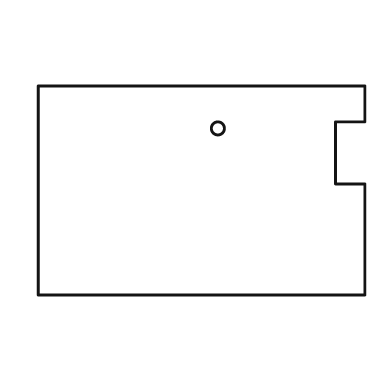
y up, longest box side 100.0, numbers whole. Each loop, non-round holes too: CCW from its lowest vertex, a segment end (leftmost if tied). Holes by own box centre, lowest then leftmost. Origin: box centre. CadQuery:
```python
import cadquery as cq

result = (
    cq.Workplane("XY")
    .moveTo(-50.0, -32.0)
    .lineTo(50.0, -32.0)
    .lineTo(50.0, 2.0)
    .lineTo(41.0, 2.0)
    .lineTo(41.0, 21.0)
    .lineTo(50.0, 21.0)
    .lineTo(50.0, 32.0)
    .lineTo(-50.0, 32.0)
    .close()
    .moveTo(5.0, 19.0)
    .circle(2.0)
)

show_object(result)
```